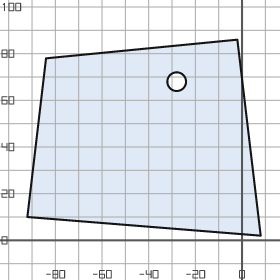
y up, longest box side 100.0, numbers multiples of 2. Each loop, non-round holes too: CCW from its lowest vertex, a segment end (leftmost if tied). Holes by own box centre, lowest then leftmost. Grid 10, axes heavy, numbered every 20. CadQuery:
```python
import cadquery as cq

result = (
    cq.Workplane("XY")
    .moveTo(8.0, 2.0)
    .lineTo(-2.0, 86.0)
    .lineTo(-84.0, 78.0)
    .lineTo(-92.0, 10.0)
    .close()
    .moveTo(-28.0, 68.0)
    .circle(4.0)
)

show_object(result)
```